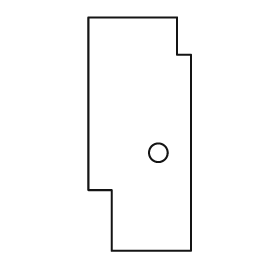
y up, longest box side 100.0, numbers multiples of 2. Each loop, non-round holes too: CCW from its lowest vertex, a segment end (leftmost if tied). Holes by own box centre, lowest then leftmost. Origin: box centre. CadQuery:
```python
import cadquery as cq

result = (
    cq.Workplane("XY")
    .moveTo(-12.0, -50.0)
    .lineTo(22.0, -50.0)
    .lineTo(22.0, 34.0)
    .lineTo(16.0, 34.0)
    .lineTo(16.0, 50.0)
    .lineTo(-22.0, 50.0)
    .lineTo(-22.0, -24.0)
    .lineTo(-12.0, -24.0)
    .close()
    .moveTo(8.0, -8.0)
    .circle(4.0)
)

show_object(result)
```